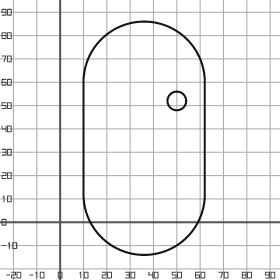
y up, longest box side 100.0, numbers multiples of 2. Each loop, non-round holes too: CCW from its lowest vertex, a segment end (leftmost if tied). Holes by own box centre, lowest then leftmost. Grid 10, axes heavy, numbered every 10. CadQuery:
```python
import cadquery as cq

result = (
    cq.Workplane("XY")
    .moveTo(10.0, 12.0)
    .threePointArc((36.0, -14.0), (62.0, 12.0))
    .lineTo(62.0, 60.0)
    .threePointArc((36.0, 86.0), (10.0, 60.0))
    .close()
    .moveTo(50.0, 52.0)
    .circle(4.0)
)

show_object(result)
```